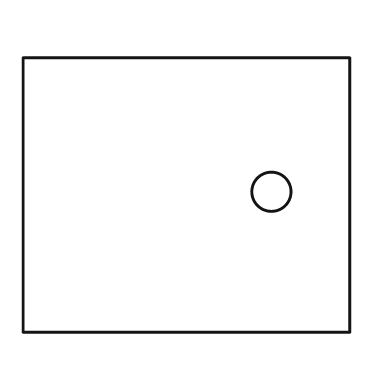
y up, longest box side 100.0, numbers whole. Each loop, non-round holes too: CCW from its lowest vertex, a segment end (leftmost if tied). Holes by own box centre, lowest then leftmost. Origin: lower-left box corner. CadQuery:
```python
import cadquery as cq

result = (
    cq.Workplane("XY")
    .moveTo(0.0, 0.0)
    .lineTo(100.0, 0.0)
    .lineTo(100.0, 84.0)
    .lineTo(0.0, 84.0)
    .close()
    .moveTo(76.0, 43.0)
    .circle(6.0)
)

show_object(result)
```